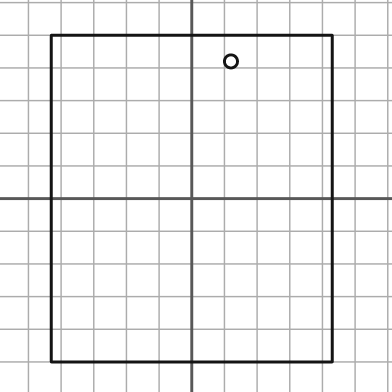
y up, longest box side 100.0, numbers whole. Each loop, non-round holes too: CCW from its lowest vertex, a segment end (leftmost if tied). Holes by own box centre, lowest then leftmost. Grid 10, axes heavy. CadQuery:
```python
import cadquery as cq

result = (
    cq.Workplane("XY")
    .moveTo(-43.0, -50.0)
    .lineTo(43.0, -50.0)
    .lineTo(43.0, 50.0)
    .lineTo(-43.0, 50.0)
    .close()
    .moveTo(12.0, 42.0)
    .circle(2.0)
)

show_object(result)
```